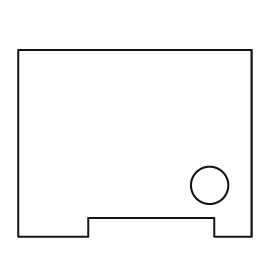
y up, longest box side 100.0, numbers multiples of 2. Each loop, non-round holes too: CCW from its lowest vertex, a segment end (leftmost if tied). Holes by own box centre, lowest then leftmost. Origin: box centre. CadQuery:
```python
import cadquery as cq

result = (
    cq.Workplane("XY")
    .moveTo(-50.0, -40.0)
    .lineTo(-20.0, -40.0)
    .lineTo(-20.0, -32.0)
    .lineTo(34.0, -32.0)
    .lineTo(34.0, -40.0)
    .lineTo(50.0, -40.0)
    .lineTo(50.0, 40.0)
    .lineTo(-50.0, 40.0)
    .close()
    .moveTo(32.0, -18.0)
    .circle(8.0)
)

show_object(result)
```